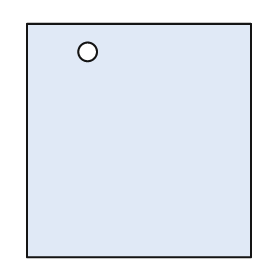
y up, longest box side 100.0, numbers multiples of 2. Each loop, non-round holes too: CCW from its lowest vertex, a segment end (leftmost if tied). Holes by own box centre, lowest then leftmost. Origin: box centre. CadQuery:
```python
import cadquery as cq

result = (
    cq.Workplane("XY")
    .moveTo(-48.0, -50.0)
    .lineTo(48.0, -50.0)
    .lineTo(48.0, 50.0)
    .lineTo(-48.0, 50.0)
    .close()
    .moveTo(-22.0, 38.0)
    .circle(4.0)
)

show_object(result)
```